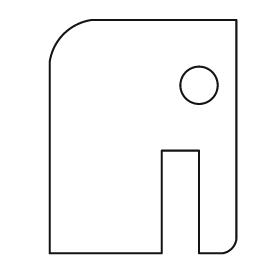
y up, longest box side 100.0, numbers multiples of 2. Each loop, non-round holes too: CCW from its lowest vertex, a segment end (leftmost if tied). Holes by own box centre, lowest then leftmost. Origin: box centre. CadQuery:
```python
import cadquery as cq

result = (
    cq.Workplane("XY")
    .moveTo(-40.0, -50.0)
    .lineTo(8.0, -50.0)
    .lineTo(8.0, -6.0)
    .lineTo(24.0, -6.0)
    .lineTo(24.0, -50.0)
    .lineTo(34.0, -50.0)
    .threePointArc((38.0, -48.0), (40.0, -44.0))
    .lineTo(40.0, 50.0)
    .lineTo(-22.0, 50.0)
    .threePointArc((-34.0, 44.0), (-40.0, 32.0))
    .close()
    .moveTo(24.0, 22.0)
    .circle(8.0)
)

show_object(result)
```